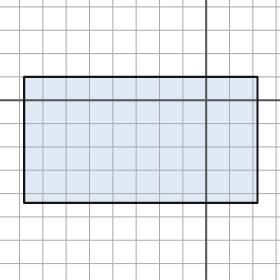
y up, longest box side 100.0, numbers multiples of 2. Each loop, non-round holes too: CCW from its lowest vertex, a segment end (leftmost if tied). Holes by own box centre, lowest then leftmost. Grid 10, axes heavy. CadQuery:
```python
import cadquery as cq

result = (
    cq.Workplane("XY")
    .moveTo(-78.0, -44.0)
    .lineTo(22.0, -44.0)
    .lineTo(22.0, 10.0)
    .lineTo(-78.0, 10.0)
    .close()
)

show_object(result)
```